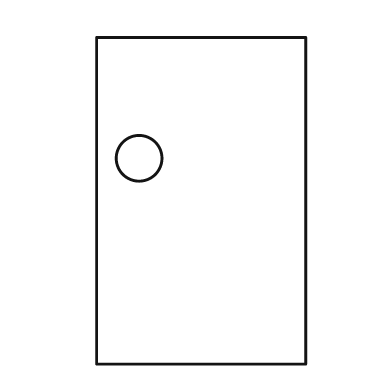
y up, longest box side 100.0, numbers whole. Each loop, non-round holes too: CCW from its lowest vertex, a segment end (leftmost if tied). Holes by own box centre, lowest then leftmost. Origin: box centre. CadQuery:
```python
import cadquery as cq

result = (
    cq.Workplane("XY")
    .moveTo(-32.0, -50.0)
    .lineTo(32.0, -50.0)
    .lineTo(32.0, 50.0)
    .lineTo(-32.0, 50.0)
    .close()
    .moveTo(-19.0, 13.0)
    .circle(7.0)
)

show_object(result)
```